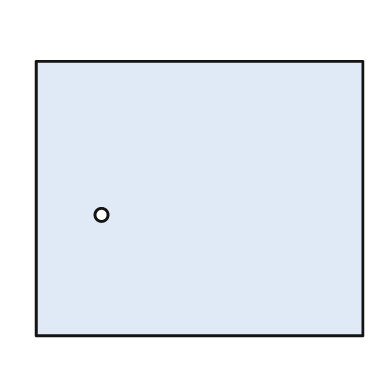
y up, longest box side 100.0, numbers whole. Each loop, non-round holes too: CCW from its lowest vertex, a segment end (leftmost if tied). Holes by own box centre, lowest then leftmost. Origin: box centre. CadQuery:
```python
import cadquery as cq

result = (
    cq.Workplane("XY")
    .moveTo(-50.0, -42.0)
    .lineTo(50.0, -42.0)
    .lineTo(50.0, 42.0)
    .lineTo(-50.0, 42.0)
    .close()
    .moveTo(-30.0, -5.0)
    .circle(2.0)
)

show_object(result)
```